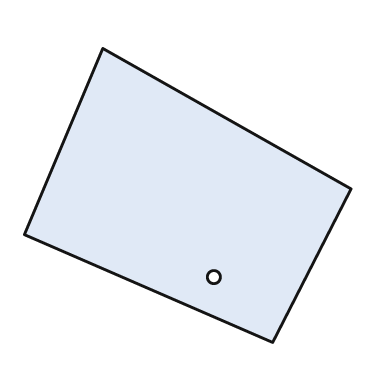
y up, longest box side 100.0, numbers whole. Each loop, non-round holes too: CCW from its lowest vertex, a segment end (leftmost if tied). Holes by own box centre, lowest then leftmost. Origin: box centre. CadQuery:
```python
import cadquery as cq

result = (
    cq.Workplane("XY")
    .moveTo(26.0, -45.0)
    .lineTo(50.0, 2.0)
    .lineTo(-26.0, 45.0)
    .lineTo(-50.0, -12.0)
    .close()
    .moveTo(8.0, -25.0)
    .circle(2.0)
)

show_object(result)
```